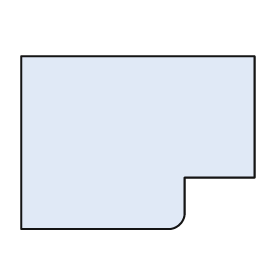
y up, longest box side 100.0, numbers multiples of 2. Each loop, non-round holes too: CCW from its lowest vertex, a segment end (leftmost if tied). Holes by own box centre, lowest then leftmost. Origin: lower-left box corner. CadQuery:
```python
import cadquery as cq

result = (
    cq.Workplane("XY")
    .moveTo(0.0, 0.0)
    .lineTo(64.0, 0.0)
    .threePointArc((68.0, 2.0), (70.0, 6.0))
    .lineTo(70.0, 22.0)
    .lineTo(100.0, 22.0)
    .lineTo(100.0, 74.0)
    .lineTo(0.0, 74.0)
    .close()
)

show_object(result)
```